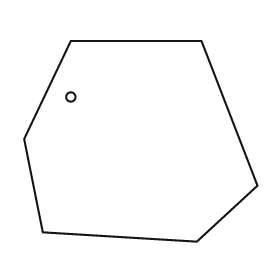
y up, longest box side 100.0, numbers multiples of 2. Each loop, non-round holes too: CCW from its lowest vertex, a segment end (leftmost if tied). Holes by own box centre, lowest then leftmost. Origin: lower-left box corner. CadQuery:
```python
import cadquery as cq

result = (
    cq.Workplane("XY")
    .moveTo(74.0, 0.0)
    .lineTo(100.0, 24.0)
    .lineTo(76.0, 86.0)
    .lineTo(20.0, 86.0)
    .lineTo(0.0, 44.0)
    .lineTo(8.0, 4.0)
    .close()
    .moveTo(20.0, 62.0)
    .circle(2.0)
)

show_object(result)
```